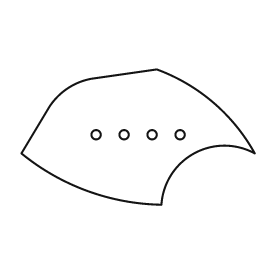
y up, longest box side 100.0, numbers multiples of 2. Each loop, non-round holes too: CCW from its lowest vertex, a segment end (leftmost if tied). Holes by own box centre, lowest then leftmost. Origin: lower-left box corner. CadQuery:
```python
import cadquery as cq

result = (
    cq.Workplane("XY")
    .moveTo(60.0, 0.0)
    .threePointArc((74.0, 22.0), (100.0, 22.0))
    .threePointArc((82.0, 44.0), (58.0, 58.0))
    .lineTo(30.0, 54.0)
    .threePointArc((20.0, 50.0), (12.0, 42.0))
    .lineTo(0.0, 22.0)
    .threePointArc((28.0, 6.0), (60.0, 0.0))
    .close()
    .moveTo(32.0, 30.0)
    .circle(2.0)
    .moveTo(44.0, 30.0)
    .circle(2.0)
    .moveTo(56.0, 30.0)
    .circle(2.0)
    .moveTo(68.0, 30.0)
    .circle(2.0)
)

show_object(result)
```